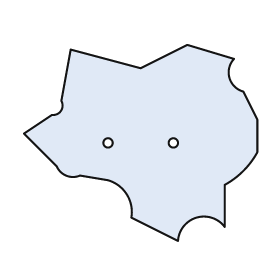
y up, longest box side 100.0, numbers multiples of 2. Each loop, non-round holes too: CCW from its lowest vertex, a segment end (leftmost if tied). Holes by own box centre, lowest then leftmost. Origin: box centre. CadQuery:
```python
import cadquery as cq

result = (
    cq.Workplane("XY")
    .moveTo(16.0, -42.0)
    .threePointArc((24.0, -32.0), (36.0, -36.0))
    .lineTo(36.0, -18.0)
    .threePointArc((44.0, -12.0), (50.0, -4.0))
    .lineTo(50.0, 10.0)
    .lineTo(44.0, 22.0)
    .threePointArc((38.0, 28.0), (40.0, 36.0))
    .lineTo(20.0, 42.0)
    .lineTo(0.0, 32.0)
    .lineTo(-30.0, 40.0)
    .lineTo(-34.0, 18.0)
    .threePointArc((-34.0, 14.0), (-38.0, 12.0))
    .lineTo(-50.0, 4.0)
    .lineTo(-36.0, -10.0)
    .threePointArc((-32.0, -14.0), (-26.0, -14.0))
    .lineTo(-14.0, -16.0)
    .threePointArc((-6.0, -22.0), (-4.0, -32.0))
    .close()
    .moveTo(-14.0, 0.0)
    .circle(2.0)
    .moveTo(14.0, 0.0)
    .circle(2.0)
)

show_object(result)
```